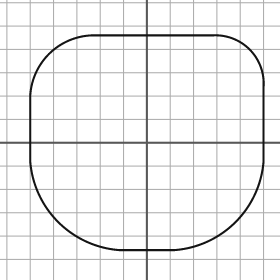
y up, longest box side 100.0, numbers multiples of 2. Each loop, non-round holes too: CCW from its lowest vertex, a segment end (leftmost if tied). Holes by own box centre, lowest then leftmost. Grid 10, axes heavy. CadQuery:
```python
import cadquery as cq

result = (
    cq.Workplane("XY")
    .moveTo(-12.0, -46.0)
    .lineTo(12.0, -46.0)
    .threePointArc((38.0, -34.0), (50.0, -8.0))
    .lineTo(50.0, 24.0)
    .threePointArc((44.0, 40.0), (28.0, 46.0))
    .lineTo(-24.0, 46.0)
    .threePointArc((-42.0, 38.0), (-50.0, 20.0))
    .lineTo(-50.0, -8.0)
    .threePointArc((-38.0, -34.0), (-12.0, -46.0))
    .close()
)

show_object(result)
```